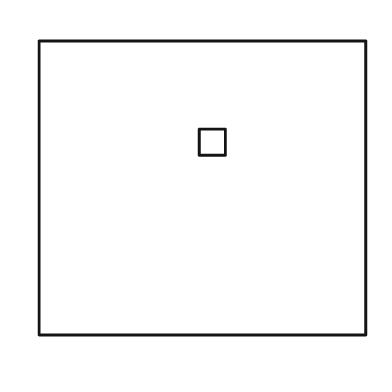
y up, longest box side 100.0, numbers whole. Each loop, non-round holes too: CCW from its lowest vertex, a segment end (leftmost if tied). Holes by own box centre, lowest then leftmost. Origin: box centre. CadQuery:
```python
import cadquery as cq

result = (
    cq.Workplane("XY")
    .moveTo(-50.0, -45.0)
    .lineTo(50.0, -45.0)
    .lineTo(50.0, 45.0)
    .lineTo(-50.0, 45.0)
    .close()
    .moveTo(-1.0, 10.0)
    .lineTo(7.0, 10.0)
    .lineTo(7.0, 18.0)
    .lineTo(-1.0, 18.0)
    .close()
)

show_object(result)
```